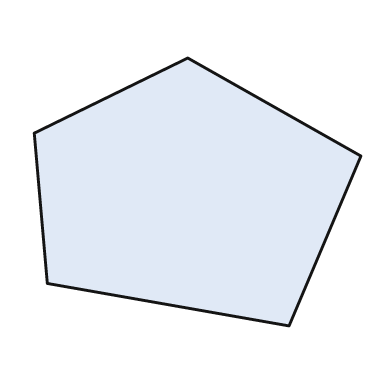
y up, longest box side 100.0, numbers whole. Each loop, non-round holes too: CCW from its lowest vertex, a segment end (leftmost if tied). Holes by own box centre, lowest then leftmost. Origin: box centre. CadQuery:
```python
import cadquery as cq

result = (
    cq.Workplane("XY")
    .moveTo(28.0, -41.0)
    .lineTo(50.0, 11.0)
    .lineTo(-3.0, 41.0)
    .lineTo(-50.0, 18.0)
    .lineTo(-46.0, -28.0)
    .close()
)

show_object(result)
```